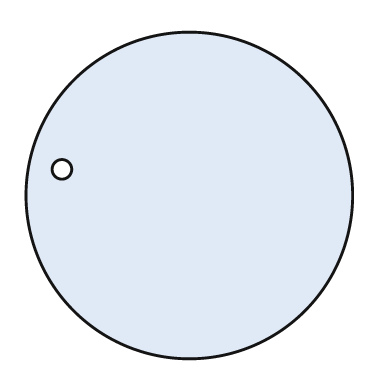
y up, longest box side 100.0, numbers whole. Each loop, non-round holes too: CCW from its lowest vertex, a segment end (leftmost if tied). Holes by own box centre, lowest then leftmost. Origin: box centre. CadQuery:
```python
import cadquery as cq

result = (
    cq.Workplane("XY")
    .moveTo(0.0, 0.0)
    .circle(50.0)
    .moveTo(-39.0, 8.0)
    .circle(3.0)
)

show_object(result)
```